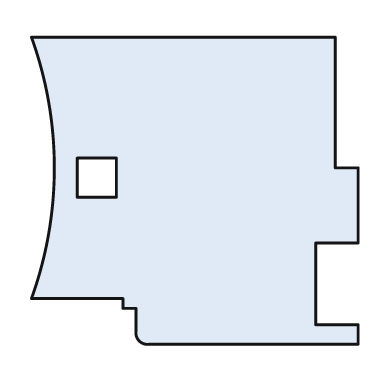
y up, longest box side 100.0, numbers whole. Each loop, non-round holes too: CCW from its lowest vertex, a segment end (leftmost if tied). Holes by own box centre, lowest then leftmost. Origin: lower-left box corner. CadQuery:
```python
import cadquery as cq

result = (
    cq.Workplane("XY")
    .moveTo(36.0, 0.0)
    .lineTo(100.0, 0.0)
    .lineTo(100.0, 6.0)
    .lineTo(87.0, 6.0)
    .lineTo(87.0, 31.0)
    .lineTo(100.0, 31.0)
    .lineTo(100.0, 54.0)
    .lineTo(93.0, 54.0)
    .lineTo(93.0, 94.0)
    .lineTo(0.0, 94.0)
    .threePointArc((7.0, 54.0), (0.0, 14.0))
    .lineTo(28.0, 14.0)
    .lineTo(28.0, 11.0)
    .lineTo(32.0, 11.0)
    .lineTo(32.0, 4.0)
    .threePointArc((33.0, 1.0), (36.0, 0.0))
    .close()
    .moveTo(14.0, 45.0)
    .lineTo(26.0, 45.0)
    .lineTo(26.0, 57.0)
    .lineTo(14.0, 57.0)
    .close()
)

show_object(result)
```